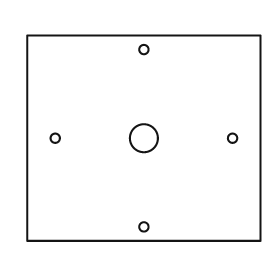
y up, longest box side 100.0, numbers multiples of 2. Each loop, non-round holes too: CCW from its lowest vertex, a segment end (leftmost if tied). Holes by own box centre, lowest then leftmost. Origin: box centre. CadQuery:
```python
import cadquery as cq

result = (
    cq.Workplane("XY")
    .moveTo(-50.0, -44.0)
    .lineTo(50.0, -44.0)
    .lineTo(50.0, 44.0)
    .lineTo(-50.0, 44.0)
    .close()
    .moveTo(0.0, -38.0)
    .circle(2.0)
    .moveTo(-38.0, 0.0)
    .circle(2.0)
    .moveTo(0.0, 0.0)
    .circle(6.0)
    .moveTo(38.0, 0.0)
    .circle(2.0)
    .moveTo(0.0, 38.0)
    .circle(2.0)
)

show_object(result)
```